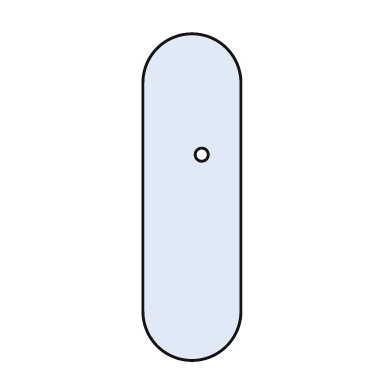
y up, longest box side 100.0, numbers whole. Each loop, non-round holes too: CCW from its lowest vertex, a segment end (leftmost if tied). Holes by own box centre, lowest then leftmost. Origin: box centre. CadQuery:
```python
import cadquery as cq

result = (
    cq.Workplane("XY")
    .moveTo(-15.0, -35.0)
    .threePointArc((0.0, -50.0), (15.0, -35.0))
    .lineTo(15.0, 35.0)
    .threePointArc((0.0, 50.0), (-15.0, 35.0))
    .close()
    .moveTo(3.0, 13.0)
    .circle(2.0)
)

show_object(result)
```